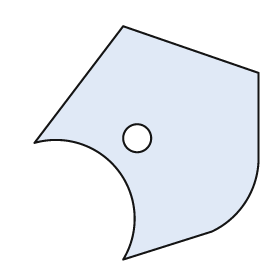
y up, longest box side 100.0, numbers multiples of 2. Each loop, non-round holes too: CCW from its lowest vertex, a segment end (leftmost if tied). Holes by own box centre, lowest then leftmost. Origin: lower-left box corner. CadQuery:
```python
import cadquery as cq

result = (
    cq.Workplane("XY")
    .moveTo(38.0, 0.0)
    .lineTo(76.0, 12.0)
    .threePointArc((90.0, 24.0), (96.0, 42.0))
    .lineTo(96.0, 80.0)
    .lineTo(38.0, 100.0)
    .lineTo(0.0, 50.0)
    .threePointArc((36.0, 38.0), (38.0, 0.0))
    .close()
    .moveTo(44.0, 52.0)
    .circle(6.0)
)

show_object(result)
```